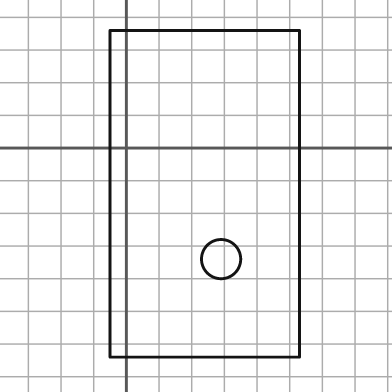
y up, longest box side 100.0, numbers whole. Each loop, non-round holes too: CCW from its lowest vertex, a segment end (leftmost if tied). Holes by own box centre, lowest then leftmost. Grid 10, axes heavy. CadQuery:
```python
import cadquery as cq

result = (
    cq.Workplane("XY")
    .moveTo(-5.0, -64.0)
    .lineTo(53.0, -64.0)
    .lineTo(53.0, 36.0)
    .lineTo(-5.0, 36.0)
    .close()
    .moveTo(29.0, -34.0)
    .circle(6.0)
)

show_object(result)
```